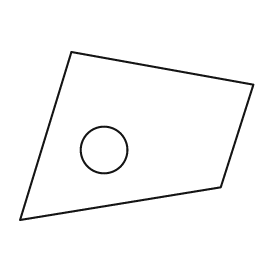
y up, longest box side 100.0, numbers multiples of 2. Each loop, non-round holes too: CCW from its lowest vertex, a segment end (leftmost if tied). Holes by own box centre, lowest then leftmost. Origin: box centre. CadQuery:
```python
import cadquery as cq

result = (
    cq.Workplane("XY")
    .moveTo(-50.0, -36.0)
    .lineTo(36.0, -22.0)
    .lineTo(50.0, 22.0)
    .lineTo(-28.0, 36.0)
    .close()
    .moveTo(-14.0, -6.0)
    .circle(10.0)
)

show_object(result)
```